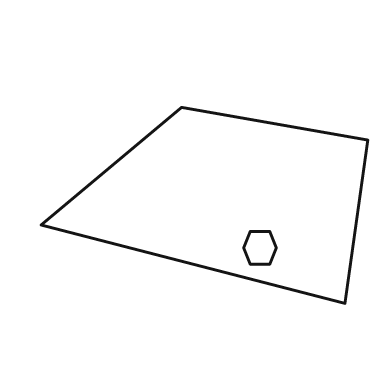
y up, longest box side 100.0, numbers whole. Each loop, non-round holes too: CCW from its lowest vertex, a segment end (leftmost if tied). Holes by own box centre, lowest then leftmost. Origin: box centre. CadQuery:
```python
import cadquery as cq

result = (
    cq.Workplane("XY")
    .moveTo(43.0, -30.0)
    .lineTo(50.0, 20.0)
    .lineTo(-7.0, 30.0)
    .lineTo(-50.0, -6.0)
    .close()
    .moveTo(14.0, -18.0)
    .lineTo(20.0, -18.0)
    .lineTo(22.0, -13.0)
    .lineTo(20.0, -8.0)
    .lineTo(14.0, -8.0)
    .lineTo(12.0, -13.0)
    .close()
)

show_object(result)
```